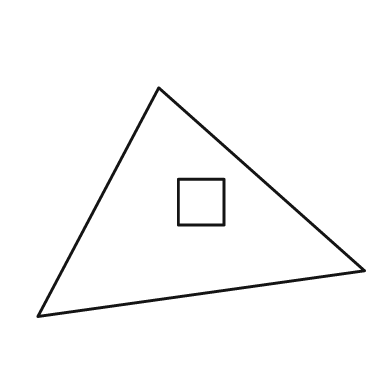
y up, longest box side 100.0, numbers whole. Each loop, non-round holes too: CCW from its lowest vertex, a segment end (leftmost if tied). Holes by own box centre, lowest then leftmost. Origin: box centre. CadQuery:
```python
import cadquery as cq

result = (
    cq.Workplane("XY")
    .moveTo(-50.0, -35.0)
    .lineTo(50.0, -21.0)
    .lineTo(-13.0, 35.0)
    .close()
    .moveTo(-7.0, -7.0)
    .lineTo(7.0, -7.0)
    .lineTo(7.0, 7.0)
    .lineTo(-7.0, 7.0)
    .close()
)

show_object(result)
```